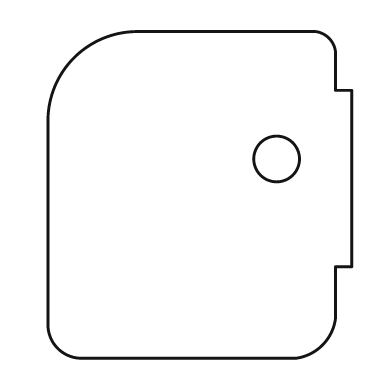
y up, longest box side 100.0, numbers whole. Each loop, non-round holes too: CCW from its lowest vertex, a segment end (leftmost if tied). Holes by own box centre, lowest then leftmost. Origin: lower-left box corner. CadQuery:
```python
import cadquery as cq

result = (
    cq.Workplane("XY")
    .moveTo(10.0, 0.0)
    .lineTo(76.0, 0.0)
    .threePointArc((84.0, 4.0), (88.0, 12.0))
    .lineTo(88.0, 28.0)
    .lineTo(93.0, 28.0)
    .lineTo(93.0, 82.0)
    .lineTo(88.0, 82.0)
    .lineTo(88.0, 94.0)
    .threePointArc((86.0, 98.0), (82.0, 100.0))
    .lineTo(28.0, 100.0)
    .threePointArc((8.0, 92.0), (0.0, 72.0))
    .lineTo(0.0, 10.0)
    .threePointArc((3.0, 3.0), (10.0, 0.0))
    .close()
    .moveTo(70.0, 61.0)
    .circle(7.0)
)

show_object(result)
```